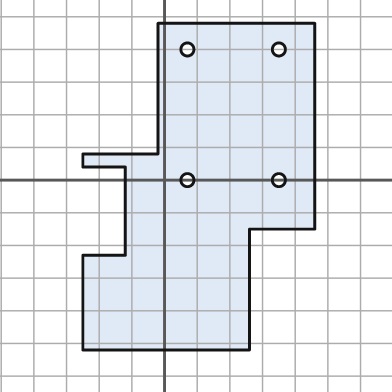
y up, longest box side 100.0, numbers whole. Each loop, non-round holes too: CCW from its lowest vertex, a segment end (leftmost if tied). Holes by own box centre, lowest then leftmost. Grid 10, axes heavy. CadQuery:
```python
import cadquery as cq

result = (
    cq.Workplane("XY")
    .moveTo(-25.0, -52.0)
    .lineTo(26.0, -52.0)
    .lineTo(26.0, -15.0)
    .lineTo(46.0, -15.0)
    .lineTo(46.0, 48.0)
    .lineTo(-2.0, 48.0)
    .lineTo(-2.0, 8.0)
    .lineTo(-25.0, 8.0)
    .lineTo(-25.0, 4.0)
    .lineTo(-12.0, 4.0)
    .lineTo(-12.0, -23.0)
    .lineTo(-25.0, -23.0)
    .close()
    .moveTo(7.0, 0.0)
    .circle(2.0)
    .moveTo(35.0, 0.0)
    .circle(2.0)
    .moveTo(7.0, 40.0)
    .circle(2.0)
    .moveTo(35.0, 40.0)
    .circle(2.0)
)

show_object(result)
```